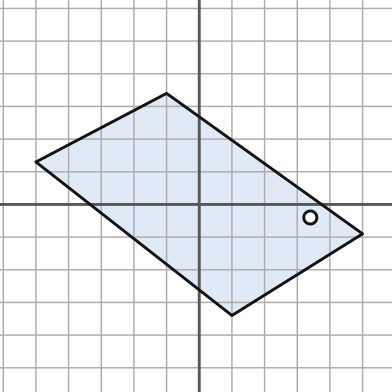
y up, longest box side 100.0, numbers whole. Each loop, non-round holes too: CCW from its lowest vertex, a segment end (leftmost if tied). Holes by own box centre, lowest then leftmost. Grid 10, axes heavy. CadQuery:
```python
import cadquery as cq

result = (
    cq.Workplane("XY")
    .moveTo(10.0, -34.0)
    .lineTo(50.0, -9.0)
    .lineTo(-10.0, 34.0)
    .lineTo(-50.0, 13.0)
    .close()
    .moveTo(34.0, -4.0)
    .circle(2.0)
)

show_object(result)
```